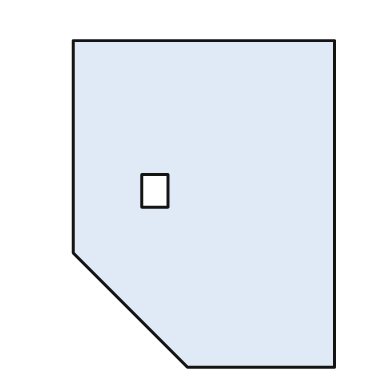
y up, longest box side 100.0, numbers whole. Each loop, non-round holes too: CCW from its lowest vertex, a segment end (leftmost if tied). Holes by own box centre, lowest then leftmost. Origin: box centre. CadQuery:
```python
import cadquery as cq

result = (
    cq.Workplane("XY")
    .moveTo(-5.0, -50.0)
    .lineTo(40.0, -50.0)
    .lineTo(40.0, 50.0)
    .lineTo(-40.0, 50.0)
    .lineTo(-40.0, -15.0)
    .close()
    .moveTo(-19.0, -1.0)
    .lineTo(-11.0, -1.0)
    .lineTo(-11.0, 9.0)
    .lineTo(-19.0, 9.0)
    .close()
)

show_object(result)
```